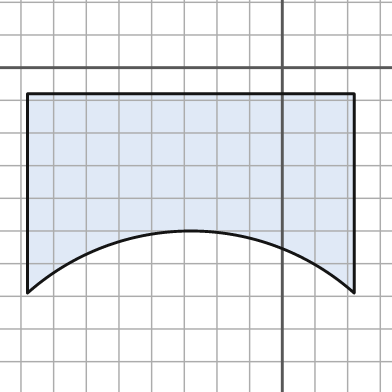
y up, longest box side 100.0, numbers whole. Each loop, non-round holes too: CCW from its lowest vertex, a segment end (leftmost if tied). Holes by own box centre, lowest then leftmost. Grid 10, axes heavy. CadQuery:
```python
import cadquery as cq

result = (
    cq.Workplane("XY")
    .moveTo(-78.0, -69.0)
    .threePointArc((-28.0, -50.0), (22.0, -69.0))
    .lineTo(22.0, -8.0)
    .lineTo(-78.0, -8.0)
    .close()
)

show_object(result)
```